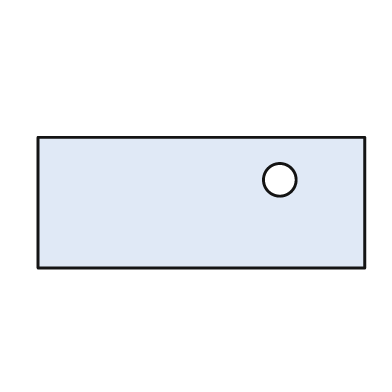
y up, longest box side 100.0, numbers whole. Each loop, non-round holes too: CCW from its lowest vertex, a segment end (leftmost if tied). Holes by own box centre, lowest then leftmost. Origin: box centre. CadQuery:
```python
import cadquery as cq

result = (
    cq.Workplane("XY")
    .moveTo(-50.0, -20.0)
    .lineTo(50.0, -20.0)
    .lineTo(50.0, 20.0)
    .lineTo(-50.0, 20.0)
    .close()
    .moveTo(24.0, 7.0)
    .circle(5.0)
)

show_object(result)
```